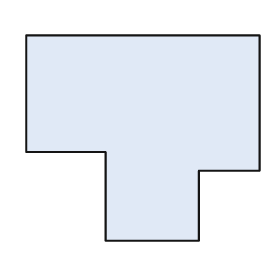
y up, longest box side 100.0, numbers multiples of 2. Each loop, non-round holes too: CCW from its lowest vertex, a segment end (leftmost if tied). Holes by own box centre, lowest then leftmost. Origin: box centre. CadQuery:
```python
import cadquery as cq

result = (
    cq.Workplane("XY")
    .moveTo(-16.0, -44.0)
    .lineTo(24.0, -44.0)
    .lineTo(24.0, -14.0)
    .lineTo(50.0, -14.0)
    .lineTo(50.0, 44.0)
    .lineTo(-50.0, 44.0)
    .lineTo(-50.0, -6.0)
    .lineTo(-16.0, -6.0)
    .close()
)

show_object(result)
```